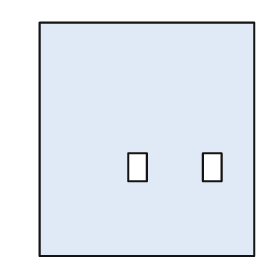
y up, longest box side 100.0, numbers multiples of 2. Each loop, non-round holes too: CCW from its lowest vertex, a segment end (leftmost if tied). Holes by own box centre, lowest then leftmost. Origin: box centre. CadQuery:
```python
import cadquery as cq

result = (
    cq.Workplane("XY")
    .moveTo(-46.0, -50.0)
    .lineTo(46.0, -50.0)
    .lineTo(46.0, 50.0)
    .lineTo(-46.0, 50.0)
    .close()
    .moveTo(-8.0, -18.0)
    .lineTo(0.0, -18.0)
    .lineTo(0.0, -6.0)
    .lineTo(-8.0, -6.0)
    .close()
    .moveTo(24.0, -18.0)
    .lineTo(32.0, -18.0)
    .lineTo(32.0, -6.0)
    .lineTo(24.0, -6.0)
    .close()
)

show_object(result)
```